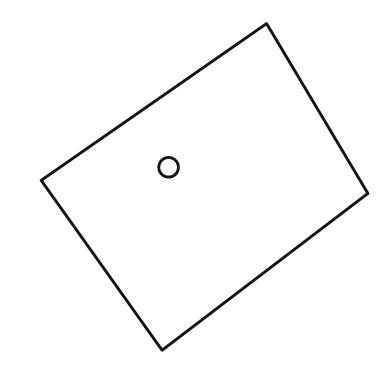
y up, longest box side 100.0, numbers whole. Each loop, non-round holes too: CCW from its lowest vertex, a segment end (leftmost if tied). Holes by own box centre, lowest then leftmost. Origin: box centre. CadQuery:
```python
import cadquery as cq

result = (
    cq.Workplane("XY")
    .moveTo(-13.0, -50.0)
    .lineTo(50.0, -2.0)
    .lineTo(19.0, 50.0)
    .lineTo(-50.0, 2.0)
    .close()
    .moveTo(-11.0, 6.0)
    .circle(3.0)
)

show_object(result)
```